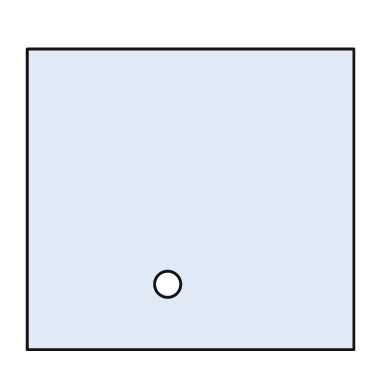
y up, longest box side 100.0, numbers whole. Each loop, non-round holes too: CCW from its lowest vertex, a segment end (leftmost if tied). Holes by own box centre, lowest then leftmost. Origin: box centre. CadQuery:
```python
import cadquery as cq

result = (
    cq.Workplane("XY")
    .moveTo(-50.0, -46.0)
    .lineTo(50.0, -46.0)
    .lineTo(50.0, 46.0)
    .lineTo(-50.0, 46.0)
    .close()
    .moveTo(-7.0, -26.0)
    .circle(4.0)
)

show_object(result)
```